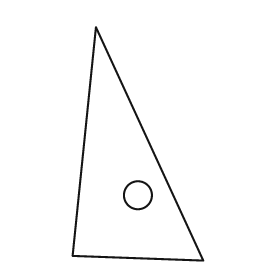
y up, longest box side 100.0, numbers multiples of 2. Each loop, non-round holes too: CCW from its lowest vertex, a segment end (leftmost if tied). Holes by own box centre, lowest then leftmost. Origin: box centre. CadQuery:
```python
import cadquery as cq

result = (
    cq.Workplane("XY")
    .moveTo(28.0, -50.0)
    .lineTo(-18.0, 50.0)
    .lineTo(-28.0, -48.0)
    .close()
    .moveTo(0.0, -22.0)
    .circle(6.0)
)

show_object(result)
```